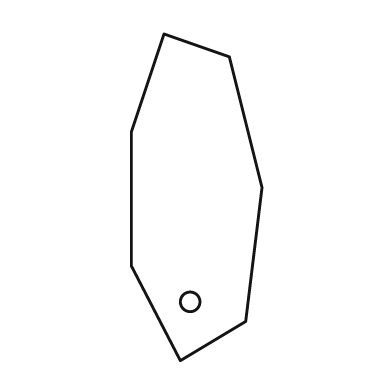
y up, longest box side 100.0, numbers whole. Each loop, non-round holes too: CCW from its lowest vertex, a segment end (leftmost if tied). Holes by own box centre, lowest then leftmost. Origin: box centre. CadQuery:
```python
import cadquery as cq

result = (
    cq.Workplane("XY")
    .moveTo(-5.0, -50.0)
    .lineTo(15.0, -38.0)
    .lineTo(20.0, 3.0)
    .lineTo(10.0, 43.0)
    .lineTo(-10.0, 50.0)
    .lineTo(-20.0, 20.0)
    .lineTo(-20.0, -21.0)
    .close()
    .moveTo(-2.0, -32.0)
    .circle(3.0)
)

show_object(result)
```